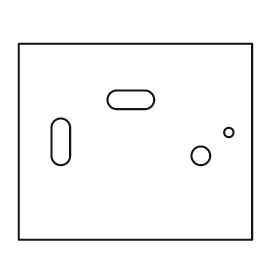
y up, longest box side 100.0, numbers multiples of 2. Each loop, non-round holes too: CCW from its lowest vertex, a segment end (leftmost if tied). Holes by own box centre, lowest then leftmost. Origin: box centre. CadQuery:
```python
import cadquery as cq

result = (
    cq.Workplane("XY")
    .moveTo(-50.0, -42.0)
    .lineTo(50.0, -42.0)
    .lineTo(50.0, 42.0)
    .lineTo(-50.0, 42.0)
    .close()
    .moveTo(28.0, -6.0)
    .circle(4.0)
    .moveTo(-36.0, -6.0)
    .threePointArc((-32.0, -10.0), (-28.0, -6.0))
    .lineTo(-28.0, 6.0)
    .threePointArc((-32.0, 10.0), (-36.0, 6.0))
    .close()
    .moveTo(40.0, 4.0)
    .circle(2.0)
    .moveTo(-8.0, 14.0)
    .lineTo(4.0, 14.0)
    .threePointArc((8.0, 18.0), (4.0, 22.0))
    .lineTo(-8.0, 22.0)
    .threePointArc((-12.0, 18.0), (-8.0, 14.0))
    .close()
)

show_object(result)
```